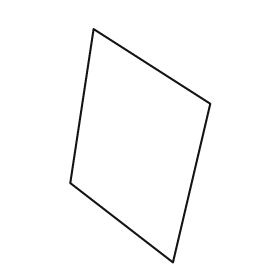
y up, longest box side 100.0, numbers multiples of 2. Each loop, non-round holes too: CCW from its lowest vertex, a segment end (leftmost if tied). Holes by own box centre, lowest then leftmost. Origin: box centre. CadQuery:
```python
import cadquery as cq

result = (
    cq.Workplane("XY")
    .moveTo(14.0, -50.0)
    .lineTo(30.0, 18.0)
    .lineTo(-20.0, 50.0)
    .lineTo(-30.0, -16.0)
    .close()
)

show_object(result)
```